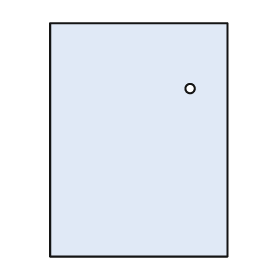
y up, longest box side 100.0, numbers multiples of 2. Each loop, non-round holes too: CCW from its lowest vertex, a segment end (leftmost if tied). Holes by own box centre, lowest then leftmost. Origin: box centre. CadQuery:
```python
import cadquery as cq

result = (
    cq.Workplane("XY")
    .moveTo(-38.0, -50.0)
    .lineTo(38.0, -50.0)
    .lineTo(38.0, 50.0)
    .lineTo(-38.0, 50.0)
    .close()
    .moveTo(22.0, 22.0)
    .circle(2.0)
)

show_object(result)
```